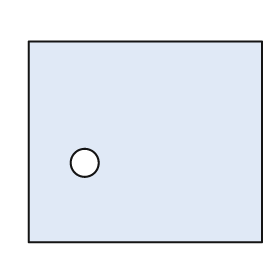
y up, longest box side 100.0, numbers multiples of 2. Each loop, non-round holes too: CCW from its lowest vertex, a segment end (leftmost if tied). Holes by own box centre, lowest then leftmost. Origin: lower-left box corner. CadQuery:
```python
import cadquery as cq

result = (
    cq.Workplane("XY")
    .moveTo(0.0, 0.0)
    .lineTo(100.0, 0.0)
    .lineTo(100.0, 86.0)
    .lineTo(0.0, 86.0)
    .close()
    .moveTo(24.0, 34.0)
    .circle(6.0)
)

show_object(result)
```